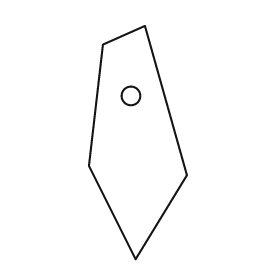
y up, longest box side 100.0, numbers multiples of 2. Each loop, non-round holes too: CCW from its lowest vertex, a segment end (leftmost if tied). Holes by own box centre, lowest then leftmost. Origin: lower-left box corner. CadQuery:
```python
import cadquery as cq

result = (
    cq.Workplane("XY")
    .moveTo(20.0, 0.0)
    .lineTo(42.0, 36.0)
    .lineTo(24.0, 100.0)
    .lineTo(6.0, 92.0)
    .lineTo(0.0, 40.0)
    .close()
    .moveTo(18.0, 70.0)
    .circle(4.0)
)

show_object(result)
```